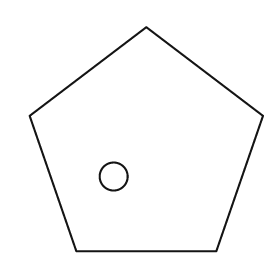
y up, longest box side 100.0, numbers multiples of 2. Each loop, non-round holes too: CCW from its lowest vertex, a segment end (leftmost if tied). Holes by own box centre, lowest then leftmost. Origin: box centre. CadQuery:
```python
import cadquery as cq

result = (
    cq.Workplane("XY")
    .moveTo(-30.0, -48.0)
    .lineTo(30.0, -48.0)
    .lineTo(50.0, 10.0)
    .lineTo(0.0, 48.0)
    .lineTo(-50.0, 10.0)
    .close()
    .moveTo(-14.0, -16.0)
    .circle(6.0)
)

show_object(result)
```